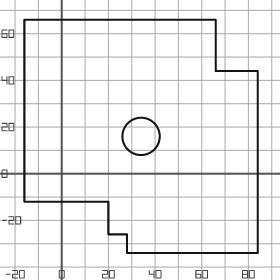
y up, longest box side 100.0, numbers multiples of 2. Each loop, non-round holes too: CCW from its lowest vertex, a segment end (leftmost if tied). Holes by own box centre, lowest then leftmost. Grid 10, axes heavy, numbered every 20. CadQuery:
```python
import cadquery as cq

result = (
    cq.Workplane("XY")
    .moveTo(28.0, -34.0)
    .lineTo(84.0, -34.0)
    .lineTo(84.0, 44.0)
    .lineTo(66.0, 44.0)
    .lineTo(66.0, 66.0)
    .lineTo(-16.0, 66.0)
    .lineTo(-16.0, -12.0)
    .lineTo(20.0, -12.0)
    .lineTo(20.0, -26.0)
    .lineTo(28.0, -26.0)
    .close()
    .moveTo(34.0, 16.0)
    .circle(8.0)
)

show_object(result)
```